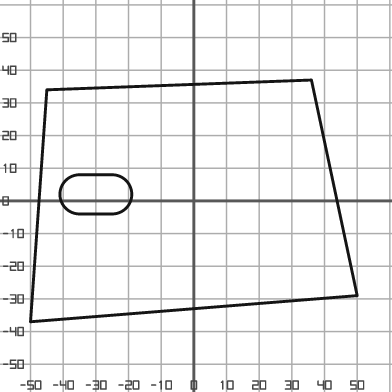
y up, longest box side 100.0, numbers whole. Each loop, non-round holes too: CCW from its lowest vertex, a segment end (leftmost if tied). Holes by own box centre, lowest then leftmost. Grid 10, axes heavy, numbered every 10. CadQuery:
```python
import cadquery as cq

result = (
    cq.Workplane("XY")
    .moveTo(-50.0, -37.0)
    .lineTo(50.0, -29.0)
    .lineTo(36.0, 37.0)
    .lineTo(-45.0, 34.0)
    .close()
    .moveTo(-35.0, -4.0)
    .lineTo(-25.0, -4.0)
    .threePointArc((-19.0, 2.0), (-25.0, 8.0))
    .lineTo(-35.0, 8.0)
    .threePointArc((-41.0, 2.0), (-35.0, -4.0))
    .close()
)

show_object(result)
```